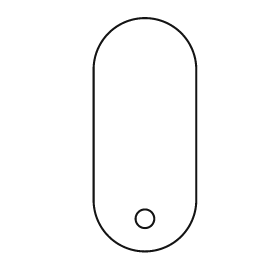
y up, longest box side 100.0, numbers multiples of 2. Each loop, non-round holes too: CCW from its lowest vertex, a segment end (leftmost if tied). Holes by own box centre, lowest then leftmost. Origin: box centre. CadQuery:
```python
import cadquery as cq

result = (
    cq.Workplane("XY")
    .moveTo(-22.0, -28.0)
    .threePointArc((0.0, -50.0), (22.0, -28.0))
    .lineTo(22.0, 28.0)
    .threePointArc((0.0, 50.0), (-22.0, 28.0))
    .close()
    .moveTo(0.0, -36.0)
    .circle(4.0)
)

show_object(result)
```